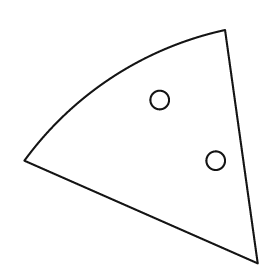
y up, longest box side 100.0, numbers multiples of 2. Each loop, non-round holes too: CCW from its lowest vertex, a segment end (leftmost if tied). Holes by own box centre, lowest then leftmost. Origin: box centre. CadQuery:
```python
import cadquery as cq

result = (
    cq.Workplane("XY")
    .moveTo(50.0, -50.0)
    .lineTo(36.0, 50.0)
    .threePointArc((-12.0, 30.0), (-50.0, -6.0))
    .close()
    .moveTo(32.0, -6.0)
    .circle(4.0)
    .moveTo(8.0, 20.0)
    .circle(4.0)
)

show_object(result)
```